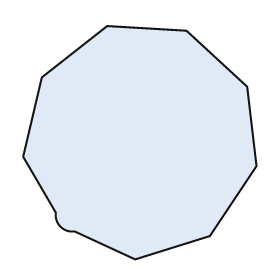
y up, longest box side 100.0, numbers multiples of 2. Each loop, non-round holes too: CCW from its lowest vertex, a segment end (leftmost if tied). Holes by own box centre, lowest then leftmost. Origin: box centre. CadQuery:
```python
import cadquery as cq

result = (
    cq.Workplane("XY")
    .moveTo(-2.0, -50.0)
    .lineTo(30.0, -40.0)
    .lineTo(50.0, -10.0)
    .lineTo(46.0, 24.0)
    .lineTo(20.0, 48.0)
    .lineTo(-14.0, 50.0)
    .lineTo(-42.0, 28.0)
    .lineTo(-50.0, -6.0)
    .lineTo(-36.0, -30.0)
    .threePointArc((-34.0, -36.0), (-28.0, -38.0))
    .close()
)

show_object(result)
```